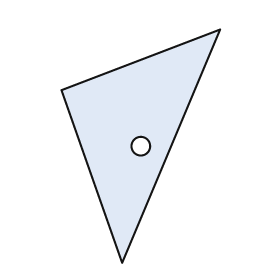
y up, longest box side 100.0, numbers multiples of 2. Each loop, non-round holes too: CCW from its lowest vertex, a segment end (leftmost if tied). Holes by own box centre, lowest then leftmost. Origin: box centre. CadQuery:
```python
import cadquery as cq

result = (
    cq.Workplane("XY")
    .moveTo(-8.0, -50.0)
    .lineTo(34.0, 50.0)
    .lineTo(-34.0, 24.0)
    .close()
    .moveTo(0.0, 0.0)
    .circle(4.0)
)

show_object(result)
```